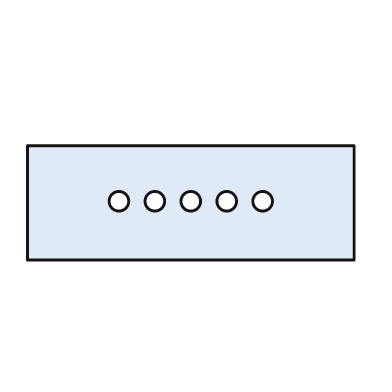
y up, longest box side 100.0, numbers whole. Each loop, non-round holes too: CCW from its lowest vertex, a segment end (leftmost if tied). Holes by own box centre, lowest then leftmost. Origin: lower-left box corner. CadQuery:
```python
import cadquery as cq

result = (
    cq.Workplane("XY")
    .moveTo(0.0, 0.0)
    .lineTo(100.0, 0.0)
    .lineTo(100.0, 35.0)
    .lineTo(0.0, 35.0)
    .close()
    .moveTo(28.0, 18.0)
    .circle(3.0)
    .moveTo(39.0, 18.0)
    .circle(3.0)
    .moveTo(50.0, 18.0)
    .circle(3.0)
    .moveTo(61.0, 18.0)
    .circle(3.0)
    .moveTo(72.0, 18.0)
    .circle(3.0)
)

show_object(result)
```